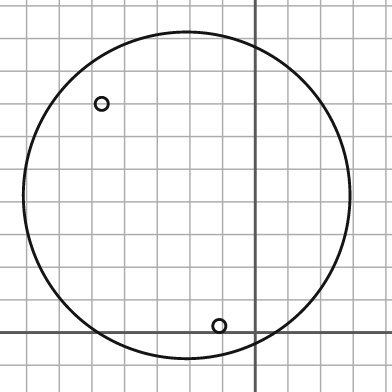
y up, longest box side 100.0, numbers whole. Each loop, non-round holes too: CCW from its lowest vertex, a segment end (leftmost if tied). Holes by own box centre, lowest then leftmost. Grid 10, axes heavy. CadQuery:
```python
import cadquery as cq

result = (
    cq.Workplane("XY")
    .moveTo(-21.0, 42.0)
    .circle(50.0)
    .moveTo(-11.0, 2.0)
    .circle(2.0)
    .moveTo(-47.0, 70.0)
    .circle(2.0)
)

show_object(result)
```